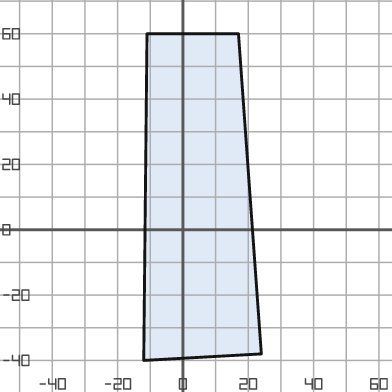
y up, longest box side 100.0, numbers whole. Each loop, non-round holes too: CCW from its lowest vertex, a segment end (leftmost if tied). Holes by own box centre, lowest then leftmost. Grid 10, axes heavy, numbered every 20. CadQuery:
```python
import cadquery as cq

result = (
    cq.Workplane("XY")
    .moveTo(-12.0, -40.0)
    .lineTo(24.0, -38.0)
    .lineTo(17.0, 60.0)
    .lineTo(-11.0, 60.0)
    .close()
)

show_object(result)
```